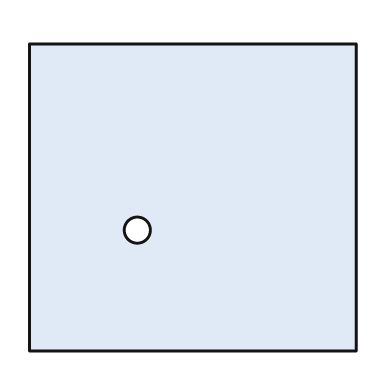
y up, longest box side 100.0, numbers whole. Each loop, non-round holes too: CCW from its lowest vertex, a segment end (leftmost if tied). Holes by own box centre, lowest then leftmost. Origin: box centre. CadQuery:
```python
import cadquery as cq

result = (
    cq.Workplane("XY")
    .moveTo(-50.0, -47.0)
    .lineTo(50.0, -47.0)
    .lineTo(50.0, 47.0)
    .lineTo(-50.0, 47.0)
    .close()
    .moveTo(-17.0, -10.0)
    .circle(4.0)
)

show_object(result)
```